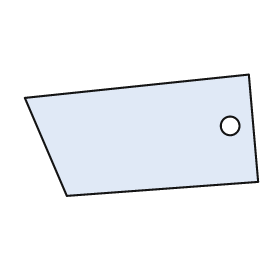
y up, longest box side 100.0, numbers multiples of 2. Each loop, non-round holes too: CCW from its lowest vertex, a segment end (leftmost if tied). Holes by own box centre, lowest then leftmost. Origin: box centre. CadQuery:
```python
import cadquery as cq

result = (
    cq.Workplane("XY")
    .moveTo(-32.0, -26.0)
    .lineTo(50.0, -20.0)
    .lineTo(46.0, 26.0)
    .lineTo(-50.0, 16.0)
    .close()
    .moveTo(38.0, 4.0)
    .circle(4.0)
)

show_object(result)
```